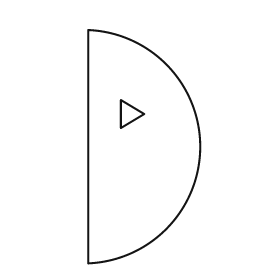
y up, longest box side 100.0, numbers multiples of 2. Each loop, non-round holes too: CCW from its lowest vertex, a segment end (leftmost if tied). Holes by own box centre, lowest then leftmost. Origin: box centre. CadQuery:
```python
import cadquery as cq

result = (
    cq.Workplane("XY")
    .moveTo(-24.0, -50.0)
    .threePointArc((24.0, 0.0), (-24.0, 50.0))
    .close()
    .moveTo(-10.0, 8.0)
    .lineTo(0.0, 14.0)
    .lineTo(-10.0, 20.0)
    .close()
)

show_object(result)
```